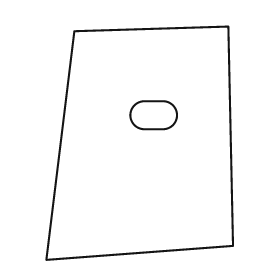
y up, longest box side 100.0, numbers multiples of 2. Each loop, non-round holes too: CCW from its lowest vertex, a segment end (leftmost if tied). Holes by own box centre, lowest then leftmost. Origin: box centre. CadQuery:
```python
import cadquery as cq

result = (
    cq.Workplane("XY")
    .moveTo(-40.0, -50.0)
    .lineTo(40.0, -44.0)
    .lineTo(38.0, 50.0)
    .lineTo(-28.0, 48.0)
    .close()
    .moveTo(2.0, 6.0)
    .lineTo(10.0, 6.0)
    .threePointArc((16.0, 12.0), (10.0, 18.0))
    .lineTo(2.0, 18.0)
    .threePointArc((-4.0, 12.0), (2.0, 6.0))
    .close()
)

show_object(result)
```